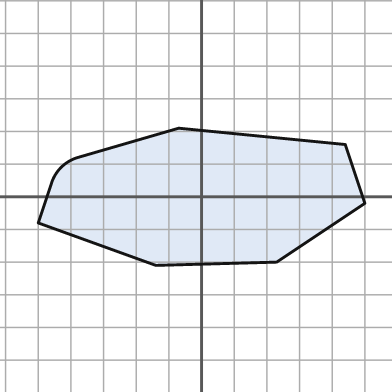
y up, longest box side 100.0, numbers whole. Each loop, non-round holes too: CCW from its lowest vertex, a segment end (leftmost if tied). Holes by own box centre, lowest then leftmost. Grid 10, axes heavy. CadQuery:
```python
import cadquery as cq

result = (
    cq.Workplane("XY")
    .moveTo(-14.0, -21.0)
    .lineTo(23.0, -20.0)
    .lineTo(50.0, -2.0)
    .lineTo(44.0, 16.0)
    .lineTo(-7.0, 21.0)
    .lineTo(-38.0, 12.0)
    .threePointArc((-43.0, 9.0), (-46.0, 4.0))
    .lineTo(-50.0, -8.0)
    .close()
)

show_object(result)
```